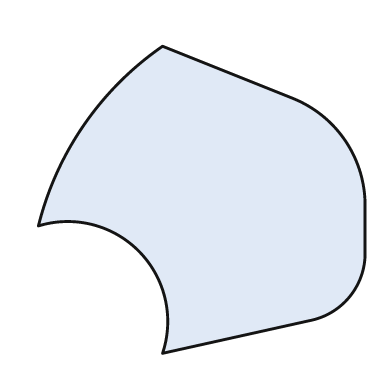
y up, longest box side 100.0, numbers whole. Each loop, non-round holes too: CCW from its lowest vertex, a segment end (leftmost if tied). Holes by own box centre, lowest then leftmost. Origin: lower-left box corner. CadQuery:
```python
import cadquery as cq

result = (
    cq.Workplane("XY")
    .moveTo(38.0, 0.0)
    .lineTo(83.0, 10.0)
    .threePointArc((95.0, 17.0), (100.0, 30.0))
    .lineTo(100.0, 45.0)
    .threePointArc((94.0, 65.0), (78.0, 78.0))
    .lineTo(38.0, 94.0)
    .threePointArc((14.0, 70.0), (0.0, 39.0))
    .threePointArc((31.0, 31.0), (38.0, 0.0))
    .close()
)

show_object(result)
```